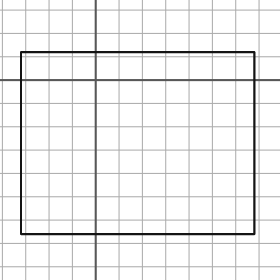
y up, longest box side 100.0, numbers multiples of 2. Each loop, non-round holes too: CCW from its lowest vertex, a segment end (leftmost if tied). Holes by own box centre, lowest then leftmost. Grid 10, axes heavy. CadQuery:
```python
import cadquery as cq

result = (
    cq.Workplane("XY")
    .moveTo(-32.0, -66.0)
    .lineTo(68.0, -66.0)
    .lineTo(68.0, 12.0)
    .lineTo(-32.0, 12.0)
    .close()
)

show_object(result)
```